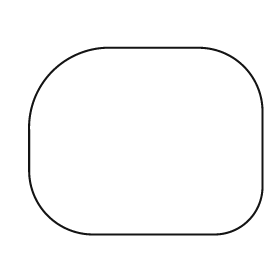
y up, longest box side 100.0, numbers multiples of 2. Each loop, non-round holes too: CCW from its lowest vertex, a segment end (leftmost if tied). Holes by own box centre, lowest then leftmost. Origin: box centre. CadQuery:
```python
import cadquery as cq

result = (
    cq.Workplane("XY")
    .moveTo(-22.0, -40.0)
    .lineTo(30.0, -40.0)
    .threePointArc((44.0, -34.0), (50.0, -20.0))
    .lineTo(50.0, 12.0)
    .threePointArc((42.0, 32.0), (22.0, 40.0))
    .lineTo(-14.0, 40.0)
    .threePointArc((-40.0, 30.0), (-50.0, 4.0))
    .lineTo(-50.0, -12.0)
    .threePointArc((-42.0, -32.0), (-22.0, -40.0))
    .close()
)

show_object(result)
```